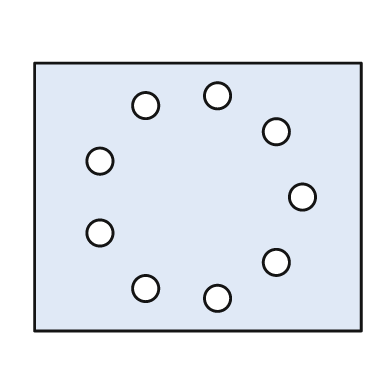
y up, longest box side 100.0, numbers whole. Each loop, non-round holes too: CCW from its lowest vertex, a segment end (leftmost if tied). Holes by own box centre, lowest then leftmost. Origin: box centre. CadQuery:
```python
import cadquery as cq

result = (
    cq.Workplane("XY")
    .moveTo(-50.0, -41.0)
    .lineTo(50.0, -41.0)
    .lineTo(50.0, 41.0)
    .lineTo(-50.0, 41.0)
    .close()
    .moveTo(6.0, -31.0)
    .circle(4.0)
    .moveTo(-16.0, -28.0)
    .circle(4.0)
    .moveTo(24.0, -20.0)
    .circle(4.0)
    .moveTo(-30.0, -11.0)
    .circle(4.0)
    .moveTo(32.0, 0.0)
    .circle(4.0)
    .moveTo(-30.0, 11.0)
    .circle(4.0)
    .moveTo(24.0, 20.0)
    .circle(4.0)
    .moveTo(-16.0, 28.0)
    .circle(4.0)
    .moveTo(6.0, 31.0)
    .circle(4.0)
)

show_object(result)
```